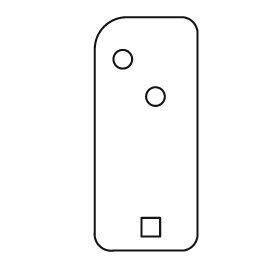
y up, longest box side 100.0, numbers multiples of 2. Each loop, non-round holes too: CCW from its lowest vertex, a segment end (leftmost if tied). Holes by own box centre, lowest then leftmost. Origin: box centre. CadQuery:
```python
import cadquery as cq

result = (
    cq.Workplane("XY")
    .moveTo(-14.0, -50.0)
    .lineTo(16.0, -50.0)
    .threePointArc((20.0, -48.0), (22.0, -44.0))
    .lineTo(22.0, 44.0)
    .threePointArc((20.0, 48.0), (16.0, 50.0))
    .lineTo(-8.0, 50.0)
    .threePointArc((-18.0, 46.0), (-22.0, 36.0))
    .lineTo(-22.0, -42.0)
    .threePointArc((-20.0, -48.0), (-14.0, -50.0))
    .close()
    .moveTo(-2.0, -44.0)
    .lineTo(6.0, -44.0)
    .lineTo(6.0, -36.0)
    .lineTo(-2.0, -36.0)
    .close()
    .moveTo(4.0, 16.0)
    .circle(4.0)
    .moveTo(-10.0, 32.0)
    .circle(4.0)
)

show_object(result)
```